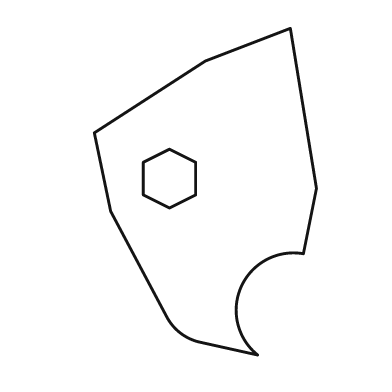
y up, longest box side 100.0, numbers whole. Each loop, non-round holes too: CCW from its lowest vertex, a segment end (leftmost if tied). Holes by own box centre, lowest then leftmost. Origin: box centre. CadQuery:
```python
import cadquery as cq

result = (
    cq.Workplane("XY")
    .moveTo(16.0, -50.0)
    .threePointArc((11.0, -29.0), (30.0, -19.0))
    .lineTo(34.0, 1.0)
    .lineTo(26.0, 50.0)
    .lineTo(0.0, 40.0)
    .lineTo(-34.0, 18.0)
    .lineTo(-29.0, -6.0)
    .lineTo(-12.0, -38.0)
    .threePointArc((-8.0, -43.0), (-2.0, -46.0))
    .close()
    .moveTo(-11.0, -5.0)
    .lineTo(-3.0, -1.0)
    .lineTo(-3.0, 9.0)
    .lineTo(-11.0, 13.0)
    .lineTo(-19.0, 9.0)
    .lineTo(-19.0, -1.0)
    .close()
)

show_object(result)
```